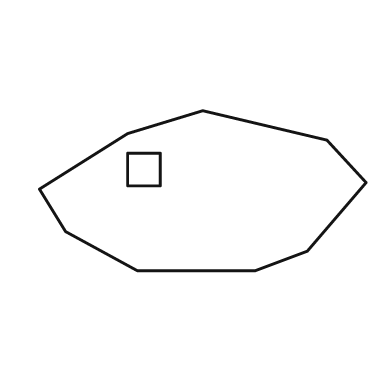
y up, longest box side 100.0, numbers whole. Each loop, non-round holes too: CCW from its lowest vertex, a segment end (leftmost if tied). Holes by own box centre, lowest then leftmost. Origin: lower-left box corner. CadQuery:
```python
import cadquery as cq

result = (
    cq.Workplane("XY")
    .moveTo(30.0, 0.0)
    .lineTo(66.0, 0.0)
    .lineTo(82.0, 6.0)
    .lineTo(100.0, 27.0)
    .lineTo(88.0, 40.0)
    .lineTo(50.0, 49.0)
    .lineTo(27.0, 42.0)
    .lineTo(0.0, 25.0)
    .lineTo(8.0, 12.0)
    .close()
    .moveTo(27.0, 26.0)
    .lineTo(37.0, 26.0)
    .lineTo(37.0, 36.0)
    .lineTo(27.0, 36.0)
    .close()
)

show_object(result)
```